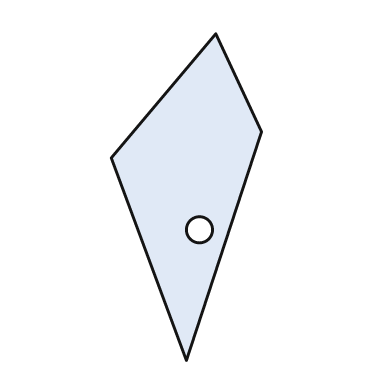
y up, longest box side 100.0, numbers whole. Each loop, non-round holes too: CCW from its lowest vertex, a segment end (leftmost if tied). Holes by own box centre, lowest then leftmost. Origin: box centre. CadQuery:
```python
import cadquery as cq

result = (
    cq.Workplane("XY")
    .moveTo(0.0, -50.0)
    .lineTo(23.0, 20.0)
    .lineTo(9.0, 50.0)
    .lineTo(-23.0, 12.0)
    .close()
    .moveTo(4.0, -10.0)
    .circle(4.0)
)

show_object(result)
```